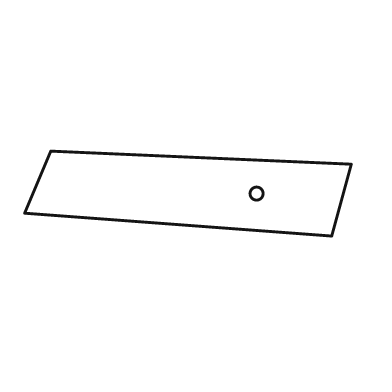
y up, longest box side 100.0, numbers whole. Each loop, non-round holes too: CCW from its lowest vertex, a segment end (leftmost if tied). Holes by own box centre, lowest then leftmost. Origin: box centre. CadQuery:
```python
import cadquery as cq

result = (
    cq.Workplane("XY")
    .moveTo(44.0, -13.0)
    .lineTo(50.0, 9.0)
    .lineTo(-42.0, 13.0)
    .lineTo(-50.0, -6.0)
    .close()
    .moveTo(21.0, 0.0)
    .circle(2.0)
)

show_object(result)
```